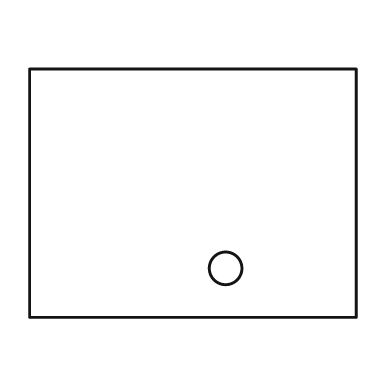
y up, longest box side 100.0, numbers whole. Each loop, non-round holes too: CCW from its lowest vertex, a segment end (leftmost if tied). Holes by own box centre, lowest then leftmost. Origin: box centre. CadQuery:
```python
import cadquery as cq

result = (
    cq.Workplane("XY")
    .moveTo(-50.0, -38.0)
    .lineTo(50.0, -38.0)
    .lineTo(50.0, 38.0)
    .lineTo(-50.0, 38.0)
    .close()
    .moveTo(10.0, -23.0)
    .circle(5.0)
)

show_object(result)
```